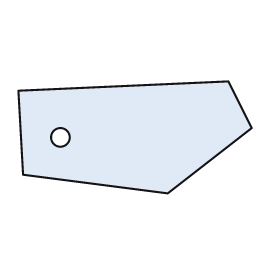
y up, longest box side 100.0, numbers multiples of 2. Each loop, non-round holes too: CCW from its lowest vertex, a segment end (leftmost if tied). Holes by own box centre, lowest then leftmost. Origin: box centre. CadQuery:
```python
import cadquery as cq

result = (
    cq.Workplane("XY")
    .moveTo(14.0, -24.0)
    .lineTo(50.0, 4.0)
    .lineTo(40.0, 24.0)
    .lineTo(-50.0, 20.0)
    .lineTo(-48.0, -16.0)
    .close()
    .moveTo(-32.0, 0.0)
    .circle(4.0)
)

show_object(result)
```